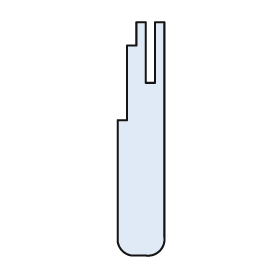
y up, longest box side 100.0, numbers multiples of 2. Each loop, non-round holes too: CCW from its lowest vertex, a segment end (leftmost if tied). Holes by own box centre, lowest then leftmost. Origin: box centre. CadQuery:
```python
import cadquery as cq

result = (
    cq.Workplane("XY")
    .moveTo(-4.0, -50.0)
    .lineTo(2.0, -50.0)
    .threePointArc((8.0, -48.0), (10.0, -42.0))
    .lineTo(10.0, 50.0)
    .lineTo(6.0, 50.0)
    .lineTo(6.0, 24.0)
    .lineTo(2.0, 24.0)
    .lineTo(2.0, 50.0)
    .lineTo(-2.0, 50.0)
    .lineTo(-2.0, 40.0)
    .lineTo(-6.0, 40.0)
    .lineTo(-6.0, 8.0)
    .lineTo(-10.0, 8.0)
    .lineTo(-10.0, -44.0)
    .threePointArc((-8.0, -48.0), (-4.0, -50.0))
    .close()
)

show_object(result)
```